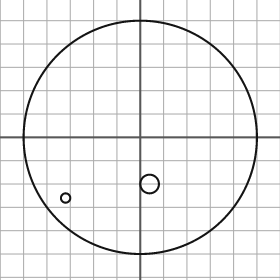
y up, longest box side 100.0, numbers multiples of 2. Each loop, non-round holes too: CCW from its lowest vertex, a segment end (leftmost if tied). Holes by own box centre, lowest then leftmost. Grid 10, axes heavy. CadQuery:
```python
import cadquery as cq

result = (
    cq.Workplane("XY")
    .moveTo(0.0, 0.0)
    .circle(50.0)
    .moveTo(-32.0, -26.0)
    .circle(2.0)
    .moveTo(4.0, -20.0)
    .circle(4.0)
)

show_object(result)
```